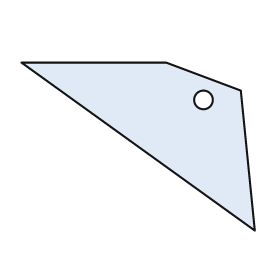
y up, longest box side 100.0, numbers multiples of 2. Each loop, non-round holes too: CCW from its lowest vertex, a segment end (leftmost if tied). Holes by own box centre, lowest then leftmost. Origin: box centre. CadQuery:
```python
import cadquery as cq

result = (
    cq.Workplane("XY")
    .moveTo(50.0, -36.0)
    .lineTo(44.0, 24.0)
    .lineTo(12.0, 36.0)
    .lineTo(-50.0, 36.0)
    .close()
    .moveTo(28.0, 20.0)
    .circle(4.0)
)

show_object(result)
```